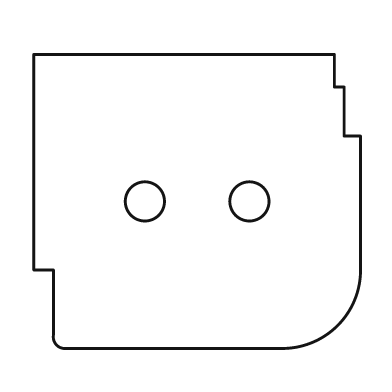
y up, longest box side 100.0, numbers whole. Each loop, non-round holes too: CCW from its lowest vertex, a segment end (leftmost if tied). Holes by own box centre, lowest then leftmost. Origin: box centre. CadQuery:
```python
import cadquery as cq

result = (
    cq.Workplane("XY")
    .moveTo(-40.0, -45.0)
    .lineTo(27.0, -45.0)
    .threePointArc((43.0, -38.0), (50.0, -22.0))
    .lineTo(50.0, 20.0)
    .lineTo(45.0, 20.0)
    .lineTo(45.0, 35.0)
    .lineTo(42.0, 35.0)
    .lineTo(42.0, 45.0)
    .lineTo(-50.0, 45.0)
    .lineTo(-50.0, -21.0)
    .lineTo(-44.0, -21.0)
    .lineTo(-44.0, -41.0)
    .threePointArc((-43.0, -44.0), (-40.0, -45.0))
    .close()
    .moveTo(-16.0, 0.0)
    .circle(6.0)
    .moveTo(16.0, 0.0)
    .circle(6.0)
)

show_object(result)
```